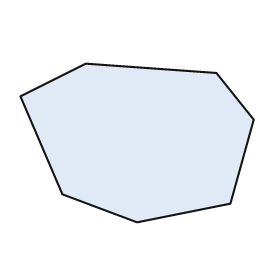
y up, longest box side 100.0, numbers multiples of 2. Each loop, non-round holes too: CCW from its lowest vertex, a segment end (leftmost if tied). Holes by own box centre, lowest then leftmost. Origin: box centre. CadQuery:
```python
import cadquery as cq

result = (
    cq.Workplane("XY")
    .moveTo(0.0, -34.0)
    .lineTo(40.0, -26.0)
    .lineTo(50.0, 10.0)
    .lineTo(34.0, 30.0)
    .lineTo(-22.0, 34.0)
    .lineTo(-50.0, 20.0)
    .lineTo(-32.0, -22.0)
    .close()
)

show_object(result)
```